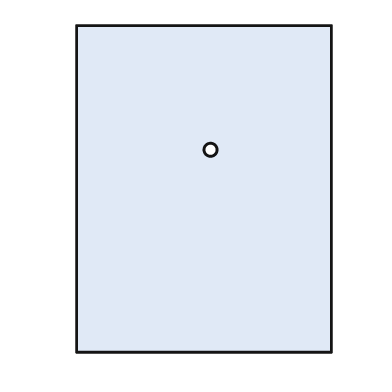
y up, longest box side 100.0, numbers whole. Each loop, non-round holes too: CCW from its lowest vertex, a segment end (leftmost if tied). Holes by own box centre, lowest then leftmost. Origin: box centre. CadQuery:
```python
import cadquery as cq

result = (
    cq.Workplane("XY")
    .moveTo(-39.0, -50.0)
    .lineTo(39.0, -50.0)
    .lineTo(39.0, 50.0)
    .lineTo(-39.0, 50.0)
    .close()
    .moveTo(2.0, 12.0)
    .circle(2.0)
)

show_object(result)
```